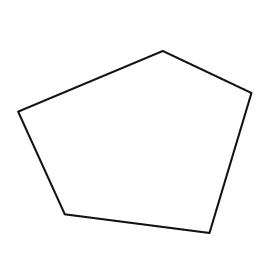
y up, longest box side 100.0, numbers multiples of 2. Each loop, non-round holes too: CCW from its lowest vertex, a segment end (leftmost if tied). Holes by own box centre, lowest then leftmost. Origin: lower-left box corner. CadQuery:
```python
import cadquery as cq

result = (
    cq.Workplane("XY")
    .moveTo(82.0, 0.0)
    .lineTo(100.0, 60.0)
    .lineTo(62.0, 78.0)
    .lineTo(0.0, 52.0)
    .lineTo(20.0, 8.0)
    .close()
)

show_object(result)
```